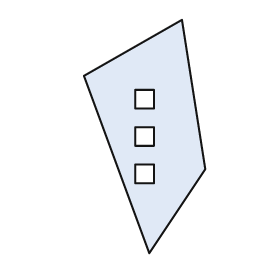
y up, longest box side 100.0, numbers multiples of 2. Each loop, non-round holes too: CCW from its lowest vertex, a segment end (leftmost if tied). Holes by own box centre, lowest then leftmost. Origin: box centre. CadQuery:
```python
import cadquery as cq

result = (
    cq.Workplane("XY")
    .moveTo(2.0, -50.0)
    .lineTo(26.0, -14.0)
    .lineTo(16.0, 50.0)
    .lineTo(-26.0, 26.0)
    .close()
    .moveTo(-4.0, -20.0)
    .lineTo(4.0, -20.0)
    .lineTo(4.0, -12.0)
    .lineTo(-4.0, -12.0)
    .close()
    .moveTo(-4.0, -4.0)
    .lineTo(4.0, -4.0)
    .lineTo(4.0, 4.0)
    .lineTo(-4.0, 4.0)
    .close()
    .moveTo(-4.0, 12.0)
    .lineTo(4.0, 12.0)
    .lineTo(4.0, 20.0)
    .lineTo(-4.0, 20.0)
    .close()
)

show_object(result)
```